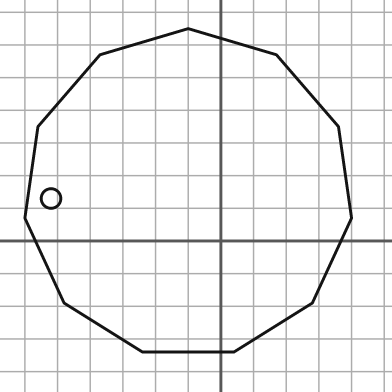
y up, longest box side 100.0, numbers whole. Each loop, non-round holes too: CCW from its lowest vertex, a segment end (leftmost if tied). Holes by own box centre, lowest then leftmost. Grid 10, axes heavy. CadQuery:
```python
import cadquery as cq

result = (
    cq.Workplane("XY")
    .moveTo(-24.0, -34.0)
    .lineTo(4.0, -34.0)
    .lineTo(28.0, -19.0)
    .lineTo(40.0, 7.0)
    .lineTo(36.0, 35.0)
    .lineTo(17.0, 57.0)
    .lineTo(-10.0, 65.0)
    .lineTo(-37.0, 57.0)
    .lineTo(-56.0, 35.0)
    .lineTo(-60.0, 7.0)
    .lineTo(-48.0, -19.0)
    .close()
    .moveTo(-52.0, 13.0)
    .circle(3.0)
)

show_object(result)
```